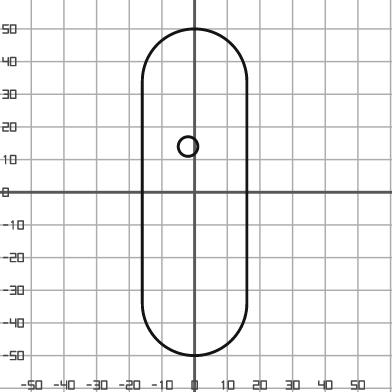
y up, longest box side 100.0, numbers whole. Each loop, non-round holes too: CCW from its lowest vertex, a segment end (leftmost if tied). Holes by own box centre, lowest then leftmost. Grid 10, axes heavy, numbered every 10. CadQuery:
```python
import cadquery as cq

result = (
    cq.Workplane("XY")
    .moveTo(-16.0, -34.0)
    .threePointArc((0.0, -50.0), (16.0, -34.0))
    .lineTo(16.0, 34.0)
    .threePointArc((0.0, 50.0), (-16.0, 34.0))
    .close()
    .moveTo(-2.0, 14.0)
    .circle(3.0)
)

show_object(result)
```